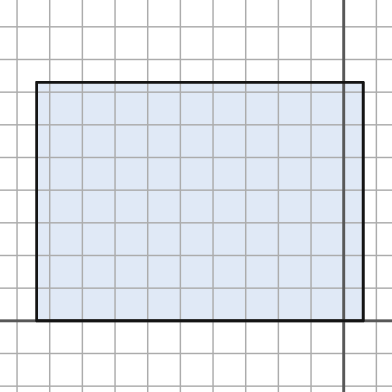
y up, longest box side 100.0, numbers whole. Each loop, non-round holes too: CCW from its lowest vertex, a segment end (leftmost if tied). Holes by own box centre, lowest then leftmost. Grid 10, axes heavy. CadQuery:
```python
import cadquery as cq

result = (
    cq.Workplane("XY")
    .moveTo(-94.0, 0.0)
    .lineTo(6.0, 0.0)
    .lineTo(6.0, 73.0)
    .lineTo(-94.0, 73.0)
    .close()
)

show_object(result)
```